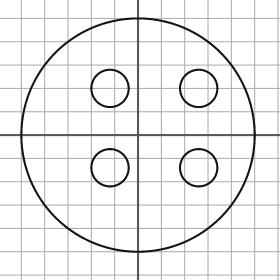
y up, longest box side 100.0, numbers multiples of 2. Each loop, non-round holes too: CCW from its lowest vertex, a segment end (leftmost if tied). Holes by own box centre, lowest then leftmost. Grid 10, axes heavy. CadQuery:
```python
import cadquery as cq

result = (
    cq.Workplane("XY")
    .moveTo(0.0, 0.0)
    .circle(50.0)
    .moveTo(-12.0, -14.0)
    .circle(8.0)
    .moveTo(26.0, -14.0)
    .circle(8.0)
    .moveTo(-12.0, 20.0)
    .circle(8.0)
    .moveTo(26.0, 20.0)
    .circle(8.0)
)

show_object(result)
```